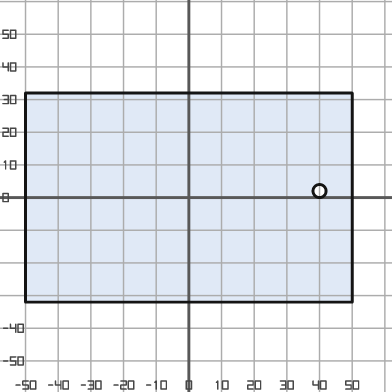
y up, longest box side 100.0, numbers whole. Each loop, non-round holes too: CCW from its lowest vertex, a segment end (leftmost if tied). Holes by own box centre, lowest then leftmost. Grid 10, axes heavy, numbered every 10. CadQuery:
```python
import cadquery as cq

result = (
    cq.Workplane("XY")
    .moveTo(-50.0, -32.0)
    .lineTo(50.0, -32.0)
    .lineTo(50.0, 32.0)
    .lineTo(-50.0, 32.0)
    .close()
    .moveTo(40.0, 2.0)
    .circle(2.0)
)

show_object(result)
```